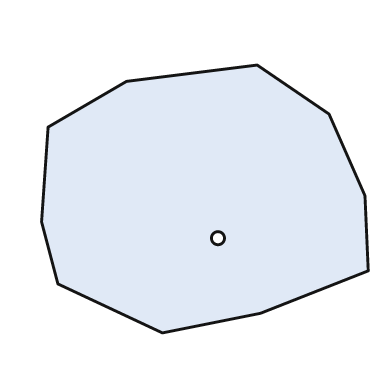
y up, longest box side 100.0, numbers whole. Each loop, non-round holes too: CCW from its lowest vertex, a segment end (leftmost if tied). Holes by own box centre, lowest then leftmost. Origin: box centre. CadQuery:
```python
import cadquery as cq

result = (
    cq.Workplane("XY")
    .moveTo(-13.0, -41.0)
    .lineTo(17.0, -35.0)
    .lineTo(50.0, -22.0)
    .lineTo(49.0, 1.0)
    .lineTo(38.0, 26.0)
    .lineTo(16.0, 41.0)
    .lineTo(-24.0, 36.0)
    .lineTo(-48.0, 22.0)
    .lineTo(-50.0, -7.0)
    .lineTo(-45.0, -26.0)
    .close()
    .moveTo(4.0, -12.0)
    .circle(2.0)
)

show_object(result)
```